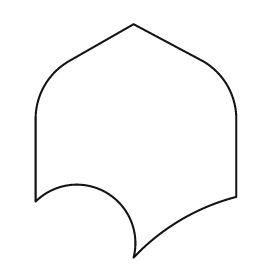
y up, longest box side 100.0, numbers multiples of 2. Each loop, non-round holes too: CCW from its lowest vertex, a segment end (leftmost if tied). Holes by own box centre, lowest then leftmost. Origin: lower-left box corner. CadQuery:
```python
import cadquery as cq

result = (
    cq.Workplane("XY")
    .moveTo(42.0, 0.0)
    .threePointArc((62.0, 16.0), (86.0, 26.0))
    .lineTo(86.0, 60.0)
    .threePointArc((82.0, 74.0), (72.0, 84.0))
    .lineTo(42.0, 100.0)
    .lineTo(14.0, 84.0)
    .threePointArc((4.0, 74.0), (0.0, 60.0))
    .lineTo(0.0, 24.0)
    .threePointArc((30.0, 28.0), (42.0, 0.0))
    .close()
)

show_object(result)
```